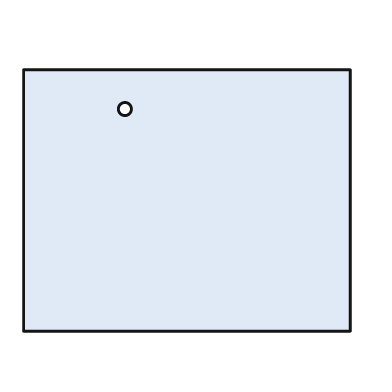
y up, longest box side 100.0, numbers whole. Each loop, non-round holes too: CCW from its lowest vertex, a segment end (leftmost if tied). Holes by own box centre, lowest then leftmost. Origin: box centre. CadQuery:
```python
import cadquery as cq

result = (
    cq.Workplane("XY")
    .moveTo(-50.0, -40.0)
    .lineTo(50.0, -40.0)
    .lineTo(50.0, 40.0)
    .lineTo(-50.0, 40.0)
    .close()
    .moveTo(-19.0, 28.0)
    .circle(2.0)
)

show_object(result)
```